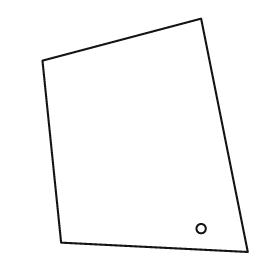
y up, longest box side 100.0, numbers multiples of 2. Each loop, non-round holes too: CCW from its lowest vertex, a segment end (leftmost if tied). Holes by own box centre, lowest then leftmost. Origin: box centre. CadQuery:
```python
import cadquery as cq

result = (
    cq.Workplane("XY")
    .moveTo(44.0, -50.0)
    .lineTo(24.0, 50.0)
    .lineTo(-44.0, 32.0)
    .lineTo(-36.0, -46.0)
    .close()
    .moveTo(24.0, -40.0)
    .circle(2.0)
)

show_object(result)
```